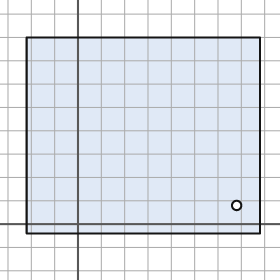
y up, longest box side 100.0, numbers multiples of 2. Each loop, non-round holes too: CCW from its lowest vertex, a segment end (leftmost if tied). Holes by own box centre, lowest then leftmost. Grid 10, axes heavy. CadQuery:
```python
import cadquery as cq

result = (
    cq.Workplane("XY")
    .moveTo(-22.0, -4.0)
    .lineTo(78.0, -4.0)
    .lineTo(78.0, 80.0)
    .lineTo(-22.0, 80.0)
    .close()
    .moveTo(68.0, 8.0)
    .circle(2.0)
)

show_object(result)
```